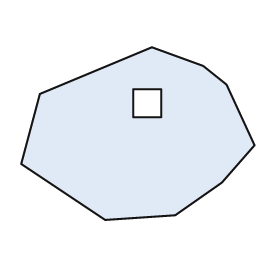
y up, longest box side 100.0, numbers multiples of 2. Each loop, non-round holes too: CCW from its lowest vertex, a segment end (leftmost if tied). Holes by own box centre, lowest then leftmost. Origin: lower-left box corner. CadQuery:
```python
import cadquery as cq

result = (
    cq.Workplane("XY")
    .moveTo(36.0, 0.0)
    .lineTo(66.0, 2.0)
    .lineTo(86.0, 16.0)
    .lineTo(100.0, 32.0)
    .lineTo(88.0, 58.0)
    .lineTo(78.0, 66.0)
    .lineTo(56.0, 74.0)
    .lineTo(8.0, 54.0)
    .lineTo(0.0, 24.0)
    .close()
    .moveTo(48.0, 44.0)
    .lineTo(60.0, 44.0)
    .lineTo(60.0, 56.0)
    .lineTo(48.0, 56.0)
    .close()
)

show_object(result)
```